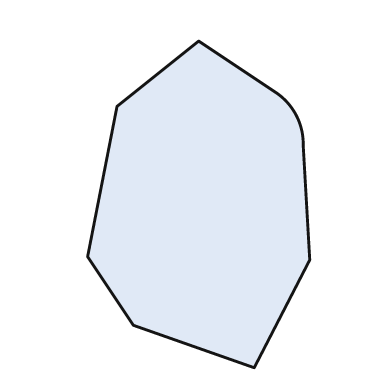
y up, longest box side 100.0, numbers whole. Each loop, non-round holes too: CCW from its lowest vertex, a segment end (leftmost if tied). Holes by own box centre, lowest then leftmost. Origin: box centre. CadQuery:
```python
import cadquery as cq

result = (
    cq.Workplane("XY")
    .moveTo(17.0, -50.0)
    .lineTo(34.0, -17.0)
    .lineTo(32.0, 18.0)
    .threePointArc((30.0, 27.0), (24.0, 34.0))
    .lineTo(0.0, 50.0)
    .lineTo(-25.0, 30.0)
    .lineTo(-34.0, -16.0)
    .lineTo(-20.0, -37.0)
    .close()
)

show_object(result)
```